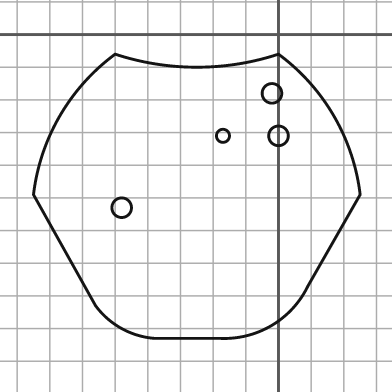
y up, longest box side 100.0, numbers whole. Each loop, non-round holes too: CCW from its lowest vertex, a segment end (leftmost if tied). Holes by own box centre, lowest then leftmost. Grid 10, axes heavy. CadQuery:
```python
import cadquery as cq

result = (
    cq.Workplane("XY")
    .moveTo(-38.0, -93.0)
    .lineTo(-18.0, -93.0)
    .threePointArc((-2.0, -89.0), (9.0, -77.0))
    .lineTo(25.0, -49.0)
    .threePointArc((17.0, -25.0), (0.0, -6.0))
    .threePointArc((-25.0, -10.0), (-50.0, -6.0))
    .threePointArc((-67.0, -25.0), (-75.0, -49.0))
    .lineTo(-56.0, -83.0)
    .threePointArc((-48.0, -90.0), (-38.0, -93.0))
    .close()
    .moveTo(-48.0, -53.0)
    .circle(3.0)
    .moveTo(-17.0, -31.0)
    .circle(2.0)
    .moveTo(0.0, -31.0)
    .circle(3.0)
    .moveTo(-2.0, -18.0)
    .circle(3.0)
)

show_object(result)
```